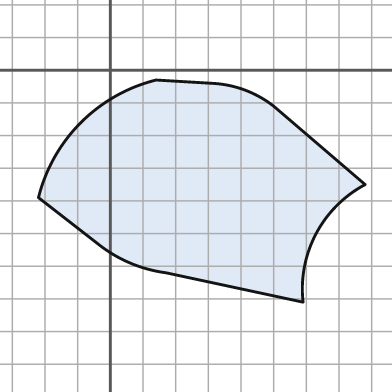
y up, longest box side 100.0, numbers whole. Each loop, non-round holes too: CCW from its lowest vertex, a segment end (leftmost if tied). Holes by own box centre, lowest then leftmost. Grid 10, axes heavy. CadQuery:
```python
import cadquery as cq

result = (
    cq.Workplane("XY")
    .moveTo(59.0, -71.0)
    .threePointArc((63.0, -50.0), (78.0, -35.0))
    .lineTo(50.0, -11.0)
    .threePointArc((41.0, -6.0), (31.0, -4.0))
    .lineTo(14.0, -3.0)
    .threePointArc((-9.0, -16.0), (-22.0, -39.0))
    .lineTo(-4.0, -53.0)
    .threePointArc((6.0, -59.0), (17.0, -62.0))
    .close()
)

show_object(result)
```